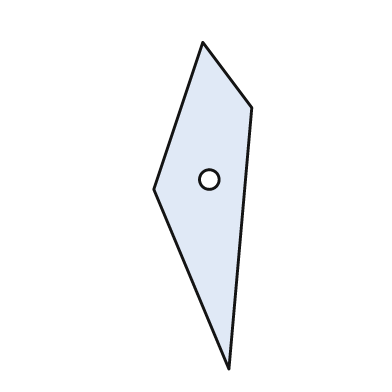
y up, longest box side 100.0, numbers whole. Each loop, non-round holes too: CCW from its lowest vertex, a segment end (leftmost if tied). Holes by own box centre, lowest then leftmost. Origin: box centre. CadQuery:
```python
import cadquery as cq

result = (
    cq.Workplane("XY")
    .moveTo(8.0, -50.0)
    .lineTo(15.0, 30.0)
    .lineTo(0.0, 50.0)
    .lineTo(-15.0, 5.0)
    .close()
    .moveTo(2.0, 8.0)
    .circle(3.0)
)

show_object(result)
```